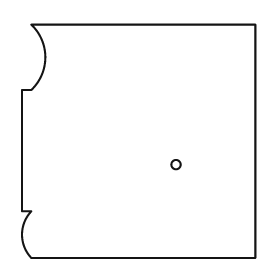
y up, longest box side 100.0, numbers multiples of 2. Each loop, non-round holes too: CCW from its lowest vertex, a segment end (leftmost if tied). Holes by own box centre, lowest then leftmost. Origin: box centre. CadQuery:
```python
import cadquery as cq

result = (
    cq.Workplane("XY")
    .moveTo(-46.0, -50.0)
    .lineTo(50.0, -50.0)
    .lineTo(50.0, 50.0)
    .lineTo(-46.0, 50.0)
    .threePointArc((-40.0, 36.0), (-46.0, 22.0))
    .lineTo(-50.0, 22.0)
    .lineTo(-50.0, -30.0)
    .lineTo(-46.0, -30.0)
    .threePointArc((-50.0, -40.0), (-46.0, -50.0))
    .close()
    .moveTo(16.0, -10.0)
    .circle(2.0)
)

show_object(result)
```